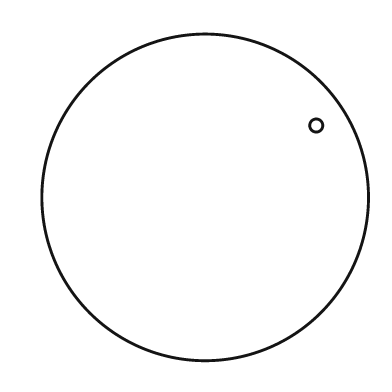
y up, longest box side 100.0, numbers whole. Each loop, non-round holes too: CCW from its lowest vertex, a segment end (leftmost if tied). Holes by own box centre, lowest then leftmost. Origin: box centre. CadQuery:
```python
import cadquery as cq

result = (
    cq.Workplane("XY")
    .moveTo(0.0, 0.0)
    .circle(50.0)
    .moveTo(34.0, 22.0)
    .circle(2.0)
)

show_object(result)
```